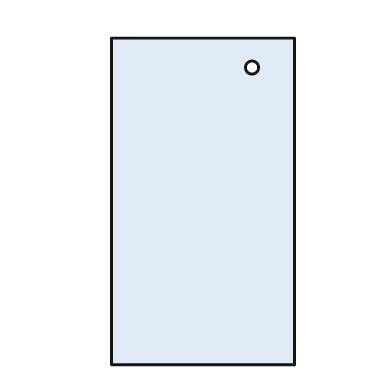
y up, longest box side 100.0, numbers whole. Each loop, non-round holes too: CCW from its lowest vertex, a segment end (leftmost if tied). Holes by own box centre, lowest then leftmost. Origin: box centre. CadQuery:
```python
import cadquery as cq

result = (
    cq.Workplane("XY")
    .moveTo(-28.0, -50.0)
    .lineTo(28.0, -50.0)
    .lineTo(28.0, 50.0)
    .lineTo(-28.0, 50.0)
    .close()
    .moveTo(15.0, 41.0)
    .circle(2.0)
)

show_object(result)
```